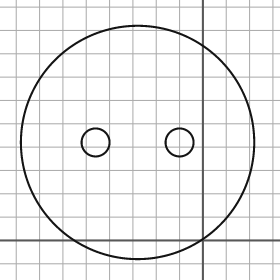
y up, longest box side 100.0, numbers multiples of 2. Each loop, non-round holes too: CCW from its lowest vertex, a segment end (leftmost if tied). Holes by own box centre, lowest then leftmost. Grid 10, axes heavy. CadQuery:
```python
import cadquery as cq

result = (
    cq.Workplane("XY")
    .moveTo(-28.0, 42.0)
    .circle(50.0)
    .moveTo(-46.0, 42.0)
    .circle(6.0)
    .moveTo(-10.0, 42.0)
    .circle(6.0)
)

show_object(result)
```